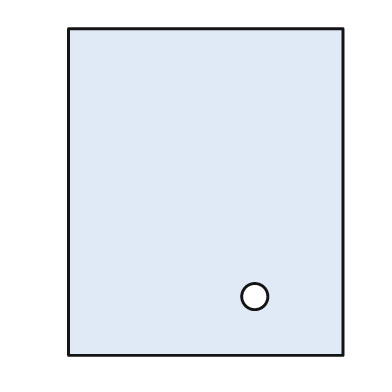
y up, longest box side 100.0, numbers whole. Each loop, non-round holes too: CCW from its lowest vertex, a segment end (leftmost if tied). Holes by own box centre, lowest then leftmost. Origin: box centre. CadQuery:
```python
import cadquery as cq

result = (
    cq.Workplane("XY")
    .moveTo(-42.0, -50.0)
    .lineTo(42.0, -50.0)
    .lineTo(42.0, 50.0)
    .lineTo(-42.0, 50.0)
    .close()
    .moveTo(15.0, -32.0)
    .circle(4.0)
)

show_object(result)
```